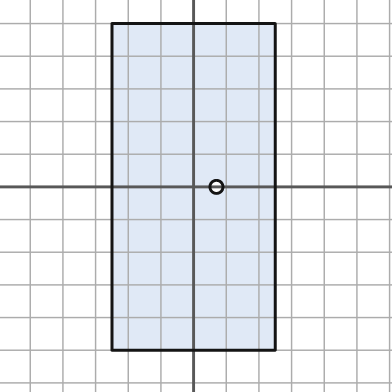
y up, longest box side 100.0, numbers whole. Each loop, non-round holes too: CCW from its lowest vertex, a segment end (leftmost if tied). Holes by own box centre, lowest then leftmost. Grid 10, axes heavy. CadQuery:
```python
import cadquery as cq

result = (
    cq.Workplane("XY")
    .moveTo(-25.0, -50.0)
    .lineTo(25.0, -50.0)
    .lineTo(25.0, 50.0)
    .lineTo(-25.0, 50.0)
    .close()
    .moveTo(7.0, 0.0)
    .circle(2.0)
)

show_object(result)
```